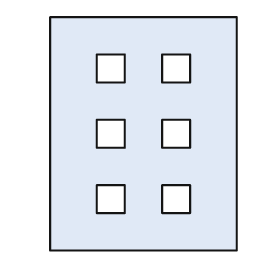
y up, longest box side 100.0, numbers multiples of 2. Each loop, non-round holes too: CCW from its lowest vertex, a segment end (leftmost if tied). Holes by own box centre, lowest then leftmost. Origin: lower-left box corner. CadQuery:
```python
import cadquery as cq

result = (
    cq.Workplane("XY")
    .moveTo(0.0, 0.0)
    .lineTo(80.0, 0.0)
    .lineTo(80.0, 100.0)
    .lineTo(0.0, 100.0)
    .close()
    .moveTo(20.0, 16.0)
    .lineTo(32.0, 16.0)
    .lineTo(32.0, 28.0)
    .lineTo(20.0, 28.0)
    .close()
    .moveTo(48.0, 16.0)
    .lineTo(60.0, 16.0)
    .lineTo(60.0, 28.0)
    .lineTo(48.0, 28.0)
    .close()
    .moveTo(20.0, 44.0)
    .lineTo(32.0, 44.0)
    .lineTo(32.0, 56.0)
    .lineTo(20.0, 56.0)
    .close()
    .moveTo(48.0, 44.0)
    .lineTo(60.0, 44.0)
    .lineTo(60.0, 56.0)
    .lineTo(48.0, 56.0)
    .close()
    .moveTo(20.0, 72.0)
    .lineTo(32.0, 72.0)
    .lineTo(32.0, 84.0)
    .lineTo(20.0, 84.0)
    .close()
    .moveTo(48.0, 72.0)
    .lineTo(60.0, 72.0)
    .lineTo(60.0, 84.0)
    .lineTo(48.0, 84.0)
    .close()
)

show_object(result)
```